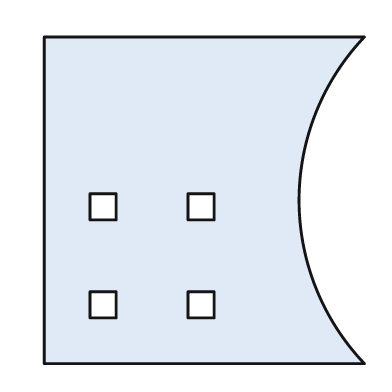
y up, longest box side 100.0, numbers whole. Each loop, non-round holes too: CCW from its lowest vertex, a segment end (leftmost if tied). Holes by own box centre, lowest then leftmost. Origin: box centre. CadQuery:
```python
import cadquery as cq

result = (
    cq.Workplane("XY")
    .moveTo(-49.0, -50.0)
    .lineTo(49.0, -50.0)
    .threePointArc((29.0, 0.0), (49.0, 50.0))
    .lineTo(-49.0, 50.0)
    .close()
    .moveTo(-35.0, -36.0)
    .lineTo(-27.0, -36.0)
    .lineTo(-27.0, -28.0)
    .lineTo(-35.0, -28.0)
    .close()
    .moveTo(-5.0, -36.0)
    .lineTo(3.0, -36.0)
    .lineTo(3.0, -28.0)
    .lineTo(-5.0, -28.0)
    .close()
    .moveTo(-35.0, -6.0)
    .lineTo(-27.0, -6.0)
    .lineTo(-27.0, 2.0)
    .lineTo(-35.0, 2.0)
    .close()
    .moveTo(-5.0, -6.0)
    .lineTo(3.0, -6.0)
    .lineTo(3.0, 2.0)
    .lineTo(-5.0, 2.0)
    .close()
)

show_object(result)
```